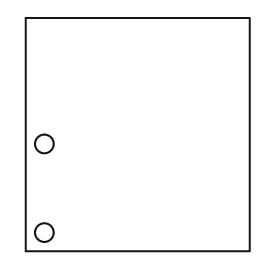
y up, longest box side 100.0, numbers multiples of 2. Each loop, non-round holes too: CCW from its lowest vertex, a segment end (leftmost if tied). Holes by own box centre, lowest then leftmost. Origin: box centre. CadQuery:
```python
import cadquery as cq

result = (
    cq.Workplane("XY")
    .moveTo(-48.0, -50.0)
    .lineTo(48.0, -50.0)
    .lineTo(48.0, 50.0)
    .lineTo(-48.0, 50.0)
    .close()
    .moveTo(-40.0, -42.0)
    .circle(4.0)
    .moveTo(-40.0, -4.0)
    .circle(4.0)
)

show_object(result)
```